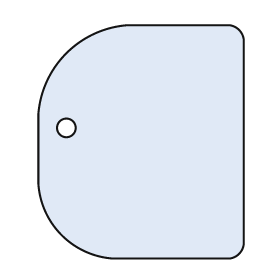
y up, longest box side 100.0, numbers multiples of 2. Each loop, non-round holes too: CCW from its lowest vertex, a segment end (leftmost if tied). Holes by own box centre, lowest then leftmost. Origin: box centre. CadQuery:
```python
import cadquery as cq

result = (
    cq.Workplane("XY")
    .moveTo(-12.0, -50.0)
    .lineTo(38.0, -50.0)
    .threePointArc((42.0, -48.0), (44.0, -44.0))
    .lineTo(44.0, 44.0)
    .threePointArc((42.0, 48.0), (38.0, 50.0))
    .lineTo(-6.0, 50.0)
    .threePointArc((-32.0, 38.0), (-44.0, 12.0))
    .lineTo(-44.0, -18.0)
    .threePointArc((-34.0, -40.0), (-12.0, -50.0))
    .close()
    .moveTo(-32.0, 6.0)
    .circle(4.0)
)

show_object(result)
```